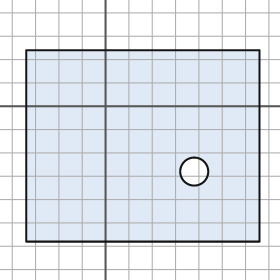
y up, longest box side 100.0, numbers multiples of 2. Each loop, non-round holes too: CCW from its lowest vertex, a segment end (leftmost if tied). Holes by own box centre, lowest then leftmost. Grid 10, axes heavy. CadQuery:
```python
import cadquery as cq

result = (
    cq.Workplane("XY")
    .moveTo(-34.0, -58.0)
    .lineTo(66.0, -58.0)
    .lineTo(66.0, 24.0)
    .lineTo(-34.0, 24.0)
    .close()
    .moveTo(38.0, -28.0)
    .circle(6.0)
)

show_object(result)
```